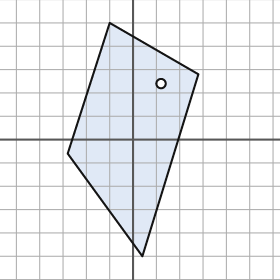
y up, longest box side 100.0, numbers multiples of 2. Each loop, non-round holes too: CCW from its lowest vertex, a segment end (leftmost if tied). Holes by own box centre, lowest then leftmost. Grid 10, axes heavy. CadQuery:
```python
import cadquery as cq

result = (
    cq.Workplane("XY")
    .moveTo(4.0, -50.0)
    .lineTo(28.0, 28.0)
    .lineTo(-10.0, 50.0)
    .lineTo(-28.0, -6.0)
    .close()
    .moveTo(12.0, 24.0)
    .circle(2.0)
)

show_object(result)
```